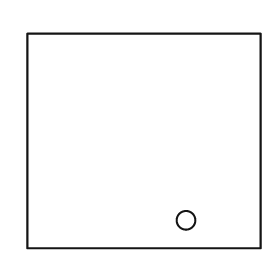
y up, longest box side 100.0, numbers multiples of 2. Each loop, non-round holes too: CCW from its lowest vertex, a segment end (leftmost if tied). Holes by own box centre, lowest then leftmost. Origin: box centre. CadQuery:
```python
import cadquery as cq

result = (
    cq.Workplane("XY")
    .moveTo(-50.0, -46.0)
    .lineTo(50.0, -46.0)
    .lineTo(50.0, 46.0)
    .lineTo(-50.0, 46.0)
    .close()
    .moveTo(18.0, -34.0)
    .circle(4.0)
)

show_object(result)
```